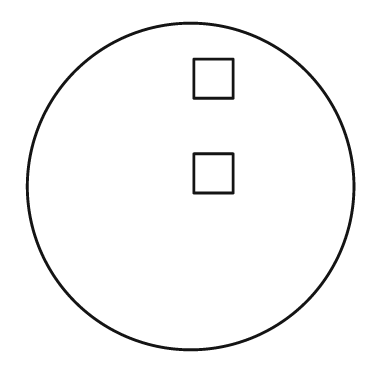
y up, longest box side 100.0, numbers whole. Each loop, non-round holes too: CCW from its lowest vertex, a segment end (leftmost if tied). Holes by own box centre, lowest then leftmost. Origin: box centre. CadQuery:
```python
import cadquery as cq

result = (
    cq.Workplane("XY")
    .moveTo(0.0, 0.0)
    .circle(50.0)
    .moveTo(1.0, -2.0)
    .lineTo(13.0, -2.0)
    .lineTo(13.0, 10.0)
    .lineTo(1.0, 10.0)
    .close()
    .moveTo(1.0, 27.0)
    .lineTo(13.0, 27.0)
    .lineTo(13.0, 39.0)
    .lineTo(1.0, 39.0)
    .close()
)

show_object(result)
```